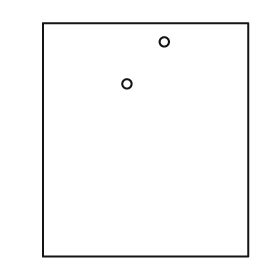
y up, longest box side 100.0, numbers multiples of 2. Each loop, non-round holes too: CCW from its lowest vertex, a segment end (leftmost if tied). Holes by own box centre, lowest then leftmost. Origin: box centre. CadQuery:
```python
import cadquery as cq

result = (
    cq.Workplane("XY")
    .moveTo(-44.0, -50.0)
    .lineTo(44.0, -50.0)
    .lineTo(44.0, 50.0)
    .lineTo(-44.0, 50.0)
    .close()
    .moveTo(-8.0, 24.0)
    .circle(2.0)
    .moveTo(8.0, 42.0)
    .circle(2.0)
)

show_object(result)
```